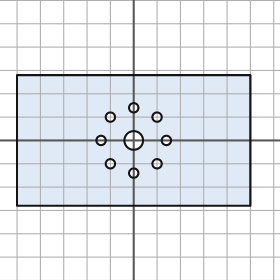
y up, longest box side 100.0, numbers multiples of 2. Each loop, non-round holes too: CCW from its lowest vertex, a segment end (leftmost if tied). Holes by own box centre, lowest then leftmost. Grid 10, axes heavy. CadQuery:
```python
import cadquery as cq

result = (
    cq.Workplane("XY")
    .moveTo(-50.0, -28.0)
    .lineTo(50.0, -28.0)
    .lineTo(50.0, 28.0)
    .lineTo(-50.0, 28.0)
    .close()
    .moveTo(0.0, -14.0)
    .circle(2.0)
    .moveTo(-10.0, -10.0)
    .circle(2.0)
    .moveTo(10.0, -10.0)
    .circle(2.0)
    .moveTo(-14.0, 0.0)
    .circle(2.0)
    .moveTo(0.0, 0.0)
    .circle(4.0)
    .moveTo(14.0, 0.0)
    .circle(2.0)
    .moveTo(-10.0, 10.0)
    .circle(2.0)
    .moveTo(10.0, 10.0)
    .circle(2.0)
    .moveTo(0.0, 14.0)
    .circle(2.0)
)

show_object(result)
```